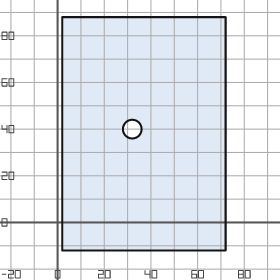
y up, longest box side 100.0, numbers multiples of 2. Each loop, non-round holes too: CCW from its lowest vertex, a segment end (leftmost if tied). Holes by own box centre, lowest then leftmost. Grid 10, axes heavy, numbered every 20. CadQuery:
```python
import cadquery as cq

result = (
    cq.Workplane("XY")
    .moveTo(2.0, -12.0)
    .lineTo(72.0, -12.0)
    .lineTo(72.0, 88.0)
    .lineTo(2.0, 88.0)
    .close()
    .moveTo(32.0, 40.0)
    .circle(4.0)
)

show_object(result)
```